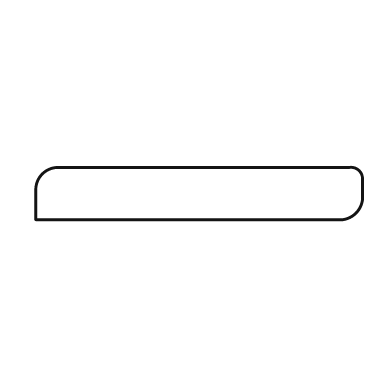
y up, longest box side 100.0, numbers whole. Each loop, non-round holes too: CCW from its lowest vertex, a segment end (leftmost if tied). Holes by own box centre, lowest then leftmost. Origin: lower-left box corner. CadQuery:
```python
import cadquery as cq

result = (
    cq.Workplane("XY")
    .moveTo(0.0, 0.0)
    .lineTo(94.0, 0.0)
    .threePointArc((98.0, 2.0), (100.0, 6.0))
    .lineTo(100.0, 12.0)
    .threePointArc((99.0, 15.0), (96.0, 16.0))
    .lineTo(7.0, 16.0)
    .threePointArc((2.0, 14.0), (0.0, 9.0))
    .close()
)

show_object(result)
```